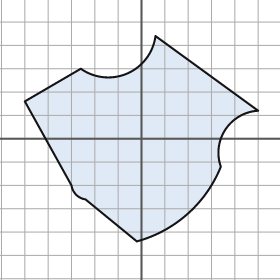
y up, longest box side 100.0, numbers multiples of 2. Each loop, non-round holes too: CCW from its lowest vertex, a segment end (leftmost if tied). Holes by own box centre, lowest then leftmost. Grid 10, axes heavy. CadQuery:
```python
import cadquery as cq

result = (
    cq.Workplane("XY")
    .moveTo(-2.0, -44.0)
    .threePointArc((20.0, -32.0), (34.0, -12.0))
    .threePointArc((36.0, 4.0), (50.0, 12.0))
    .lineTo(6.0, 44.0)
    .threePointArc((-6.0, 28.0), (-26.0, 30.0))
    .lineTo(-50.0, 16.0)
    .lineTo(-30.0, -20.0)
    .threePointArc((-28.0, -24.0), (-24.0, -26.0))
    .close()
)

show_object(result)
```